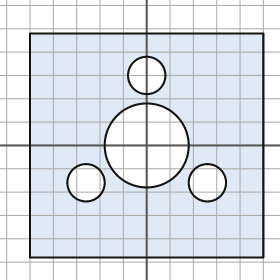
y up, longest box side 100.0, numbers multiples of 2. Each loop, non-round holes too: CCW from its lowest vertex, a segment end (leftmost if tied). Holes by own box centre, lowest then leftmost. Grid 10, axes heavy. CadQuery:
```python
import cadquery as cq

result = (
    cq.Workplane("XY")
    .moveTo(-50.0, -48.0)
    .lineTo(50.0, -48.0)
    .lineTo(50.0, 48.0)
    .lineTo(-50.0, 48.0)
    .close()
    .moveTo(-26.0, -16.0)
    .circle(8.0)
    .moveTo(26.0, -16.0)
    .circle(8.0)
    .moveTo(0.0, 0.0)
    .circle(18.0)
    .moveTo(0.0, 30.0)
    .circle(8.0)
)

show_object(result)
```